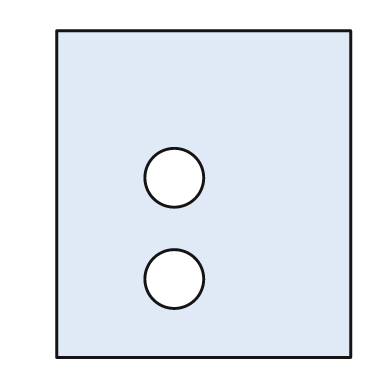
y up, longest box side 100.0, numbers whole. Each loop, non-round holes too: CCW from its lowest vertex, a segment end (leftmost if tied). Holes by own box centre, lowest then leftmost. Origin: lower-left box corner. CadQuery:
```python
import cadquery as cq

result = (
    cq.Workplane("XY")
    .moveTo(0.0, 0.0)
    .lineTo(90.0, 0.0)
    .lineTo(90.0, 100.0)
    .lineTo(0.0, 100.0)
    .close()
    .moveTo(36.0, 24.0)
    .circle(9.0)
    .moveTo(36.0, 55.0)
    .circle(9.0)
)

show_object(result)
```